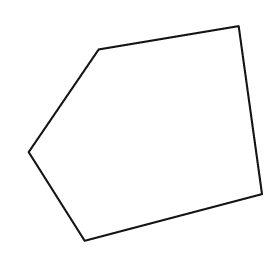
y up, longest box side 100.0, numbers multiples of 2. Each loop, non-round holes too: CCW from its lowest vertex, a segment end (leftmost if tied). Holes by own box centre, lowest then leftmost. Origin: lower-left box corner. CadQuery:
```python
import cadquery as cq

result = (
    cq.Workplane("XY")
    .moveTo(24.0, 0.0)
    .lineTo(100.0, 20.0)
    .lineTo(90.0, 92.0)
    .lineTo(30.0, 82.0)
    .lineTo(0.0, 38.0)
    .close()
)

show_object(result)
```